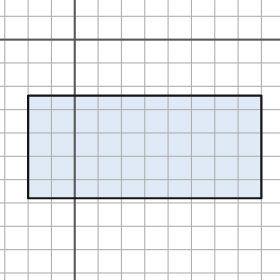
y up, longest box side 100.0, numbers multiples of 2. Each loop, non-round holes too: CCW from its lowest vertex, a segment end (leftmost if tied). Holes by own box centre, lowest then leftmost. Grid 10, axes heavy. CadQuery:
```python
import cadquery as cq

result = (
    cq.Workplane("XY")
    .moveTo(-20.0, -68.0)
    .lineTo(80.0, -68.0)
    .lineTo(80.0, -24.0)
    .lineTo(-20.0, -24.0)
    .close()
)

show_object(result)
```